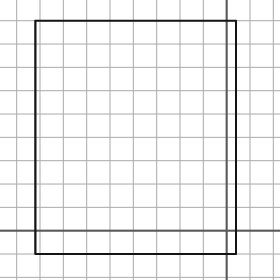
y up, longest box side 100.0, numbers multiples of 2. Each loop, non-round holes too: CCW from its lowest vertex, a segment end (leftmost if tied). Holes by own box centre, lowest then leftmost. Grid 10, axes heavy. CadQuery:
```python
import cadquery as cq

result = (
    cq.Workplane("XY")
    .moveTo(-82.0, -10.0)
    .lineTo(4.0, -10.0)
    .lineTo(4.0, 90.0)
    .lineTo(-82.0, 90.0)
    .close()
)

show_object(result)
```